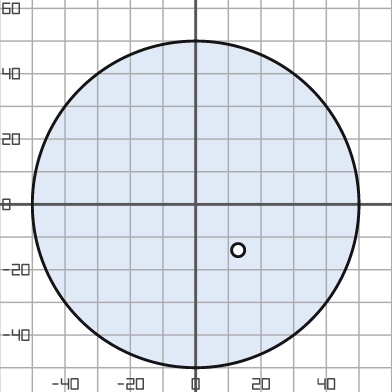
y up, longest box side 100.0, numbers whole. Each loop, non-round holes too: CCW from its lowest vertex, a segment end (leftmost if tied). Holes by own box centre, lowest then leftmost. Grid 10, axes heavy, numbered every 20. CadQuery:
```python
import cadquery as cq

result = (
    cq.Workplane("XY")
    .moveTo(0.0, 0.0)
    .circle(50.0)
    .moveTo(13.0, -14.0)
    .circle(2.0)
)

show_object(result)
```